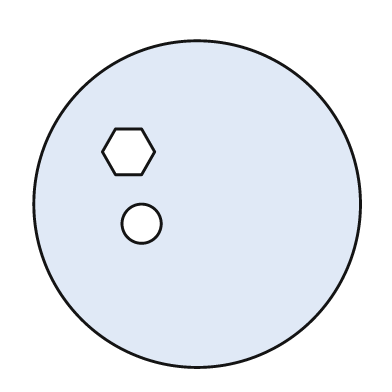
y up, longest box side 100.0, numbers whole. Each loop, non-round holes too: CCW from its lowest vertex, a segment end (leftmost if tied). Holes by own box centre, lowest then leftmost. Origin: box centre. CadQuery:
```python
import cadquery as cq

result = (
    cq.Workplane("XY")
    .moveTo(0.0, 0.0)
    .circle(50.0)
    .moveTo(-17.0, -6.0)
    .circle(6.0)
    .moveTo(-25.0, 9.0)
    .lineTo(-17.0, 9.0)
    .lineTo(-13.0, 16.0)
    .lineTo(-17.0, 23.0)
    .lineTo(-25.0, 23.0)
    .lineTo(-29.0, 16.0)
    .close()
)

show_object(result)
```